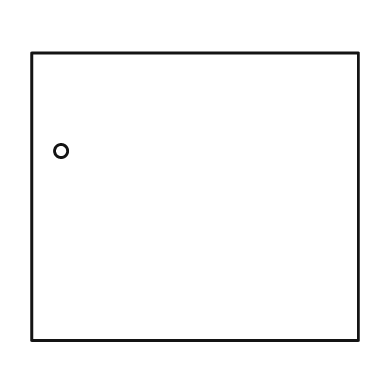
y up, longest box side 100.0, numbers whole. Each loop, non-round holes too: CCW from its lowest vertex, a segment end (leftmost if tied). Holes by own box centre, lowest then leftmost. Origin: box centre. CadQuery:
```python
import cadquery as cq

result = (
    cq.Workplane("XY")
    .moveTo(-50.0, -44.0)
    .lineTo(50.0, -44.0)
    .lineTo(50.0, 44.0)
    .lineTo(-50.0, 44.0)
    .close()
    .moveTo(-41.0, 14.0)
    .circle(2.0)
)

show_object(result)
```